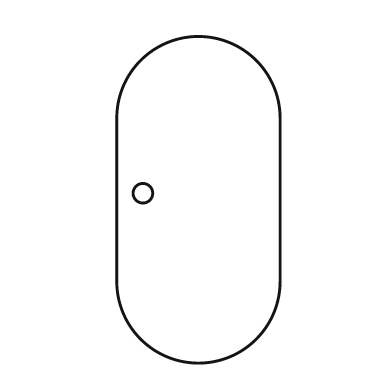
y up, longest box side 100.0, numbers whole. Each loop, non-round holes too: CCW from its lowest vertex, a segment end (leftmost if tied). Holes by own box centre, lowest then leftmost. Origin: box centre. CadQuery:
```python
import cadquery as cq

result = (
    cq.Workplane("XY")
    .moveTo(-25.0, -25.0)
    .threePointArc((0.0, -50.0), (25.0, -25.0))
    .lineTo(25.0, 25.0)
    .threePointArc((0.0, 50.0), (-25.0, 25.0))
    .close()
    .moveTo(-17.0, 2.0)
    .circle(3.0)
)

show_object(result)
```